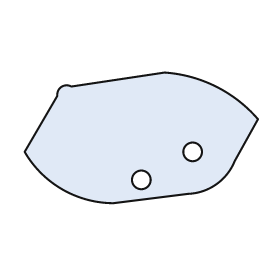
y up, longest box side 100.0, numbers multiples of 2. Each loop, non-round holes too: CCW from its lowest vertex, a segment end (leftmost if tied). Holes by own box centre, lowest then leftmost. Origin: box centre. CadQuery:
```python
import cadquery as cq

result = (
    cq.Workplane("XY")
    .moveTo(-12.0, -28.0)
    .lineTo(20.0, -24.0)
    .threePointArc((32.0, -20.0), (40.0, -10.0))
    .lineTo(50.0, 8.0)
    .threePointArc((32.0, 22.0), (10.0, 28.0))
    .lineTo(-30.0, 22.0)
    .threePointArc((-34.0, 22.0), (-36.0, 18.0))
    .lineTo(-50.0, -6.0)
    .threePointArc((-34.0, -22.0), (-12.0, -28.0))
    .close()
    .moveTo(0.0, -18.0)
    .circle(4.0)
    .moveTo(22.0, -6.0)
    .circle(4.0)
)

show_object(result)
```